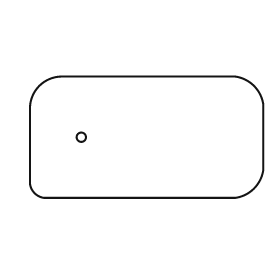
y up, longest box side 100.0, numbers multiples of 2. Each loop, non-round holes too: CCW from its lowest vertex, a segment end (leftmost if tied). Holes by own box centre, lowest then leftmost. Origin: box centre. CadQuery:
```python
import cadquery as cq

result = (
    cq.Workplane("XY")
    .moveTo(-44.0, -26.0)
    .lineTo(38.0, -26.0)
    .threePointArc((46.0, -22.0), (50.0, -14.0))
    .lineTo(50.0, 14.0)
    .threePointArc((46.0, 22.0), (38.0, 26.0))
    .lineTo(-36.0, 26.0)
    .threePointArc((-46.0, 22.0), (-50.0, 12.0))
    .lineTo(-50.0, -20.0)
    .threePointArc((-48.0, -24.0), (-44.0, -26.0))
    .close()
    .moveTo(-28.0, 0.0)
    .circle(2.0)
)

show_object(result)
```